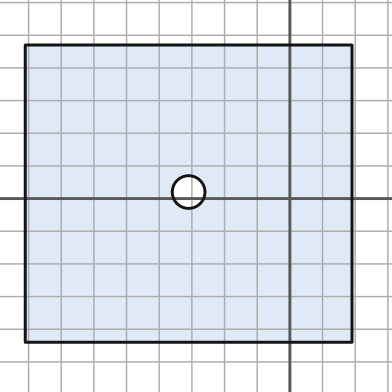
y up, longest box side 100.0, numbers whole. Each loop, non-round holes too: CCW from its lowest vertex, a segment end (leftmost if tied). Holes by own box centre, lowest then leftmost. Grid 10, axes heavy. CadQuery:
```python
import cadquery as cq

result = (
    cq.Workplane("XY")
    .moveTo(-81.0, -44.0)
    .lineTo(19.0, -44.0)
    .lineTo(19.0, 47.0)
    .lineTo(-81.0, 47.0)
    .close()
    .moveTo(-31.0, 2.0)
    .circle(5.0)
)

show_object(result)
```